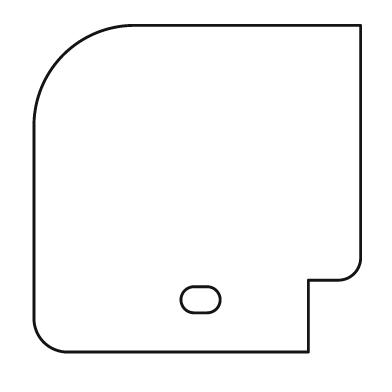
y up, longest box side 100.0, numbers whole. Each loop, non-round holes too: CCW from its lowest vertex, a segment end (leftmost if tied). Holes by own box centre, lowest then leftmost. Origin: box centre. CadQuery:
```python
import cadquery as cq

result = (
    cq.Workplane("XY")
    .moveTo(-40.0, -50.0)
    .lineTo(34.0, -50.0)
    .lineTo(34.0, -28.0)
    .lineTo(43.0, -28.0)
    .threePointArc((48.0, -26.0), (50.0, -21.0))
    .lineTo(50.0, 50.0)
    .lineTo(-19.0, 50.0)
    .threePointArc((-41.0, 41.0), (-50.0, 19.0))
    .lineTo(-50.0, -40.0)
    .threePointArc((-47.0, -47.0), (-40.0, -50.0))
    .close()
    .moveTo(-1.0, -38.0)
    .lineTo(3.0, -38.0)
    .threePointArc((7.0, -34.0), (3.0, -30.0))
    .lineTo(-1.0, -30.0)
    .threePointArc((-5.0, -34.0), (-1.0, -38.0))
    .close()
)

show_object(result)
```